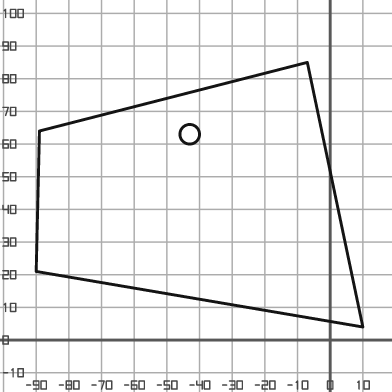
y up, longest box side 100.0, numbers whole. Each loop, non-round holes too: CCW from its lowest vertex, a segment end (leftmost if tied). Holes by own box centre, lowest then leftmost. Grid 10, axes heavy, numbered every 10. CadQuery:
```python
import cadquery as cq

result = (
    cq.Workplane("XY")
    .moveTo(10.0, 4.0)
    .lineTo(-7.0, 85.0)
    .lineTo(-89.0, 64.0)
    .lineTo(-90.0, 21.0)
    .close()
    .moveTo(-43.0, 63.0)
    .circle(3.0)
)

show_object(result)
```